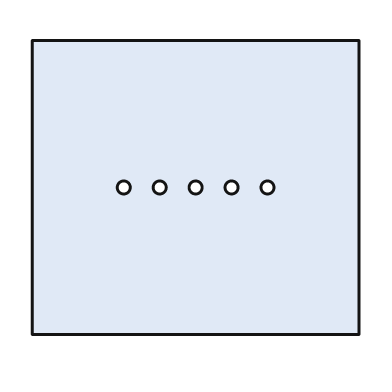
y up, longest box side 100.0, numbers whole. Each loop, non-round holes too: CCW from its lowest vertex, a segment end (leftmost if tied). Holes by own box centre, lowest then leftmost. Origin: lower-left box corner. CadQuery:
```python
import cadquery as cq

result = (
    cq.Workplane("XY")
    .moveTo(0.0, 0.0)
    .lineTo(100.0, 0.0)
    .lineTo(100.0, 90.0)
    .lineTo(0.0, 90.0)
    .close()
    .moveTo(28.0, 45.0)
    .circle(2.0)
    .moveTo(39.0, 45.0)
    .circle(2.0)
    .moveTo(50.0, 45.0)
    .circle(2.0)
    .moveTo(61.0, 45.0)
    .circle(2.0)
    .moveTo(72.0, 45.0)
    .circle(2.0)
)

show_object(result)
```